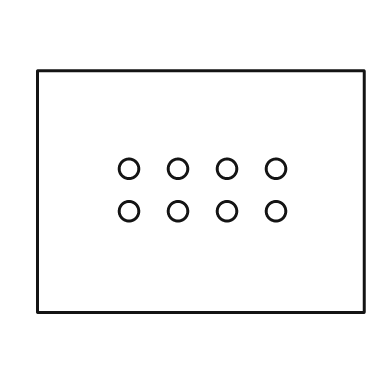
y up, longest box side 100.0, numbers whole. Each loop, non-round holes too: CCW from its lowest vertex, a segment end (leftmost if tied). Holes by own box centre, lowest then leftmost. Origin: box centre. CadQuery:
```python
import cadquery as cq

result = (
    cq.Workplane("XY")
    .moveTo(-50.0, -37.0)
    .lineTo(50.0, -37.0)
    .lineTo(50.0, 37.0)
    .lineTo(-50.0, 37.0)
    .close()
    .moveTo(-22.0, -6.0)
    .circle(3.0)
    .moveTo(-7.0, -6.0)
    .circle(3.0)
    .moveTo(8.0, -6.0)
    .circle(3.0)
    .moveTo(23.0, -6.0)
    .circle(3.0)
    .moveTo(-22.0, 7.0)
    .circle(3.0)
    .moveTo(-7.0, 7.0)
    .circle(3.0)
    .moveTo(8.0, 7.0)
    .circle(3.0)
    .moveTo(23.0, 7.0)
    .circle(3.0)
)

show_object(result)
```